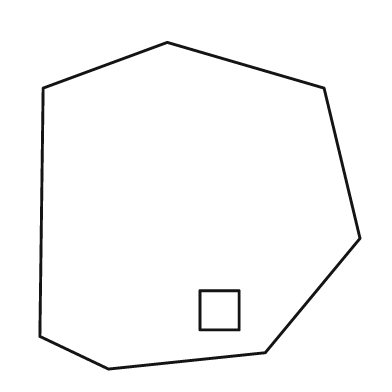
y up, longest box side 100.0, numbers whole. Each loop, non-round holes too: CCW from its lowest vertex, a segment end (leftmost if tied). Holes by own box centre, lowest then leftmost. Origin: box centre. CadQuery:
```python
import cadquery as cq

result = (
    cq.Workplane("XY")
    .moveTo(-28.0, -50.0)
    .lineTo(20.0, -45.0)
    .lineTo(49.0, -10.0)
    .lineTo(38.0, 36.0)
    .lineTo(-10.0, 50.0)
    .lineTo(-48.0, 36.0)
    .lineTo(-49.0, -40.0)
    .close()
    .moveTo(0.0, -38.0)
    .lineTo(12.0, -38.0)
    .lineTo(12.0, -26.0)
    .lineTo(0.0, -26.0)
    .close()
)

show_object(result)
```